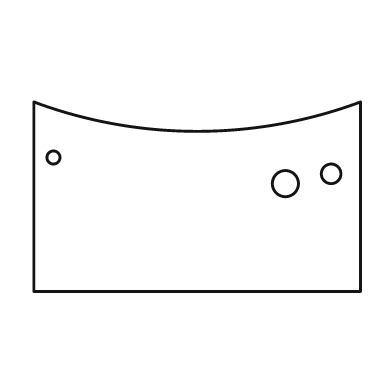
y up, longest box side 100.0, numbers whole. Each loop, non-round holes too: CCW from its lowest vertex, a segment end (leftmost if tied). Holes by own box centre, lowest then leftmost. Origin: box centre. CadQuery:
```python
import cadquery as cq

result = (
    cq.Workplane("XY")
    .moveTo(-50.0, -29.0)
    .lineTo(50.0, -29.0)
    .lineTo(50.0, 29.0)
    .threePointArc((0.0, 20.0), (-50.0, 29.0))
    .close()
    .moveTo(27.0, 4.0)
    .circle(4.0)
    .moveTo(41.0, 7.0)
    .circle(3.0)
    .moveTo(-44.0, 12.0)
    .circle(2.0)
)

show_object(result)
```